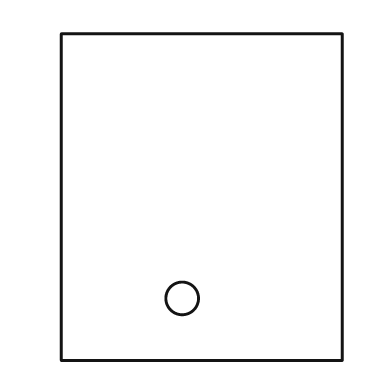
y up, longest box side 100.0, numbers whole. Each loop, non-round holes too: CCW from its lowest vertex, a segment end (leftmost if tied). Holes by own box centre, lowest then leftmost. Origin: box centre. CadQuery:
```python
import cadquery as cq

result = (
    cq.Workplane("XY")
    .moveTo(-43.0, -50.0)
    .lineTo(43.0, -50.0)
    .lineTo(43.0, 50.0)
    .lineTo(-43.0, 50.0)
    .close()
    .moveTo(-6.0, -31.0)
    .circle(5.0)
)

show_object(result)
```